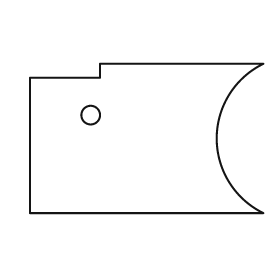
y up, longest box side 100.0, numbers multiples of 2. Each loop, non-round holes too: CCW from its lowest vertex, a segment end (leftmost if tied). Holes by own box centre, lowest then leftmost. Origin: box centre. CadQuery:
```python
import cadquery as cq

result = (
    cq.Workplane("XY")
    .moveTo(-50.0, -32.0)
    .lineTo(50.0, -32.0)
    .threePointArc((30.0, 0.0), (50.0, 32.0))
    .lineTo(-20.0, 32.0)
    .lineTo(-20.0, 26.0)
    .lineTo(-50.0, 26.0)
    .close()
    .moveTo(-24.0, 10.0)
    .circle(4.0)
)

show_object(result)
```